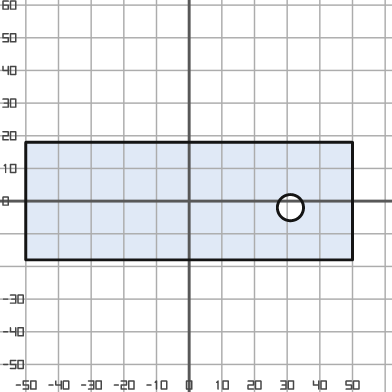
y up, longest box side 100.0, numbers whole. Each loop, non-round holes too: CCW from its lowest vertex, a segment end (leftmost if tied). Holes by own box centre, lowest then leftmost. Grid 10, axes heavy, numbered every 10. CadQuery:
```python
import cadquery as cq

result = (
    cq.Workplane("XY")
    .moveTo(-50.0, -18.0)
    .lineTo(50.0, -18.0)
    .lineTo(50.0, 18.0)
    .lineTo(-50.0, 18.0)
    .close()
    .moveTo(31.0, -2.0)
    .circle(4.0)
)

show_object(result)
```